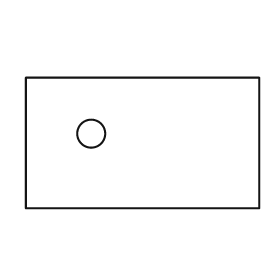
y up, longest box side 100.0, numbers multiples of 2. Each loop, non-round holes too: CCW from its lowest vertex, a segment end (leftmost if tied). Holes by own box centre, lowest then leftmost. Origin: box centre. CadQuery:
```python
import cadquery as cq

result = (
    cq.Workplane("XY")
    .moveTo(-50.0, -28.0)
    .lineTo(50.0, -28.0)
    .lineTo(50.0, 28.0)
    .lineTo(-50.0, 28.0)
    .close()
    .moveTo(-22.0, 4.0)
    .circle(6.0)
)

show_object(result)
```